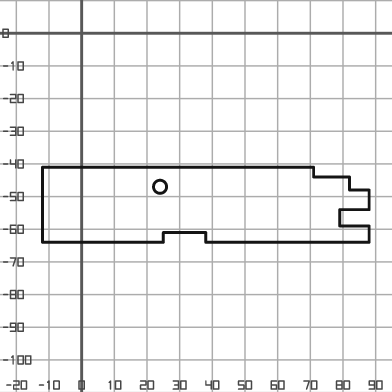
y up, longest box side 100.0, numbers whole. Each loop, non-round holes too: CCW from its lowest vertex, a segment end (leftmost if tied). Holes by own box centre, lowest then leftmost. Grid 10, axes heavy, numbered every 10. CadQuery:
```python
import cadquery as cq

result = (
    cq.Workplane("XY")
    .moveTo(-12.0, -64.0)
    .lineTo(25.0, -64.0)
    .lineTo(25.0, -61.0)
    .lineTo(38.0, -61.0)
    .lineTo(38.0, -64.0)
    .lineTo(88.0, -64.0)
    .lineTo(88.0, -59.0)
    .lineTo(79.0, -59.0)
    .lineTo(79.0, -54.0)
    .lineTo(88.0, -54.0)
    .lineTo(88.0, -48.0)
    .lineTo(82.0, -48.0)
    .lineTo(82.0, -44.0)
    .lineTo(71.0, -44.0)
    .lineTo(71.0, -41.0)
    .lineTo(-12.0, -41.0)
    .close()
    .moveTo(24.0, -47.0)
    .circle(2.0)
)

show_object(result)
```